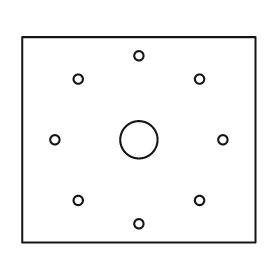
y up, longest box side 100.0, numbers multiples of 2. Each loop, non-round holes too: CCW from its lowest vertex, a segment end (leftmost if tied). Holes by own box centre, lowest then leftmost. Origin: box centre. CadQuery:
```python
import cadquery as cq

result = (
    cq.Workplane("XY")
    .moveTo(-50.0, -44.0)
    .lineTo(50.0, -44.0)
    .lineTo(50.0, 44.0)
    .lineTo(-50.0, 44.0)
    .close()
    .moveTo(0.0, -36.0)
    .circle(2.0)
    .moveTo(-26.0, -26.0)
    .circle(2.0)
    .moveTo(26.0, -26.0)
    .circle(2.0)
    .moveTo(-36.0, 0.0)
    .circle(2.0)
    .moveTo(0.0, 0.0)
    .circle(8.0)
    .moveTo(36.0, 0.0)
    .circle(2.0)
    .moveTo(-26.0, 26.0)
    .circle(2.0)
    .moveTo(26.0, 26.0)
    .circle(2.0)
    .moveTo(0.0, 36.0)
    .circle(2.0)
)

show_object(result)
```